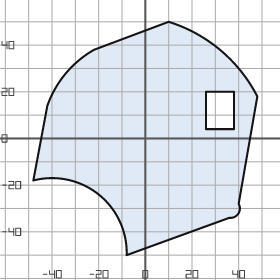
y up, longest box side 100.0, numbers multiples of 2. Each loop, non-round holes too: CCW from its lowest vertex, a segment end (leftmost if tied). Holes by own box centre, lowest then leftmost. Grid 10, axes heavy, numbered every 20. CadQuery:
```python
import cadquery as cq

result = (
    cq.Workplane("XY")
    .moveTo(-8.0, -50.0)
    .lineTo(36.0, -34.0)
    .threePointArc((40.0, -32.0), (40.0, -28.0))
    .lineTo(48.0, 18.0)
    .threePointArc((32.0, 38.0), (10.0, 50.0))
    .lineTo(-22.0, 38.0)
    .threePointArc((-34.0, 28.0), (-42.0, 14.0))
    .lineTo(-48.0, -18.0)
    .threePointArc((-20.0, -24.0), (-8.0, -50.0))
    .close()
    .moveTo(26.0, 4.0)
    .lineTo(38.0, 4.0)
    .lineTo(38.0, 20.0)
    .lineTo(26.0, 20.0)
    .close()
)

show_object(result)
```